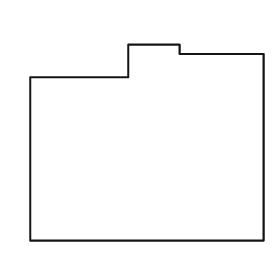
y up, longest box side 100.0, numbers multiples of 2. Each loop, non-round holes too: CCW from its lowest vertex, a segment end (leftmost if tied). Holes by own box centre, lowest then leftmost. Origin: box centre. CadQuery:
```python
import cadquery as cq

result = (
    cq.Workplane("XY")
    .moveTo(-50.0, -42.0)
    .lineTo(50.0, -42.0)
    .lineTo(50.0, 38.0)
    .lineTo(14.0, 38.0)
    .lineTo(14.0, 42.0)
    .lineTo(-8.0, 42.0)
    .lineTo(-8.0, 28.0)
    .lineTo(-50.0, 28.0)
    .close()
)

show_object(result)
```